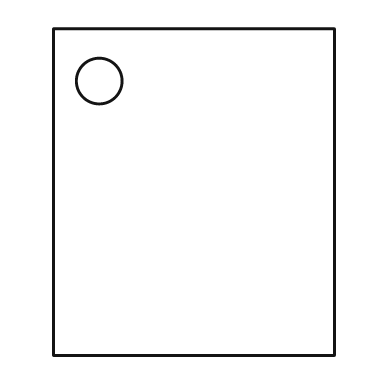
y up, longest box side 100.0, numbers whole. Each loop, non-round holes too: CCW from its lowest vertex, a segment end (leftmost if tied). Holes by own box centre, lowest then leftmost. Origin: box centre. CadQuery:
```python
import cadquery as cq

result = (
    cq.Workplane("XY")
    .moveTo(-43.0, -50.0)
    .lineTo(43.0, -50.0)
    .lineTo(43.0, 50.0)
    .lineTo(-43.0, 50.0)
    .close()
    .moveTo(-29.0, 34.0)
    .circle(7.0)
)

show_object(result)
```